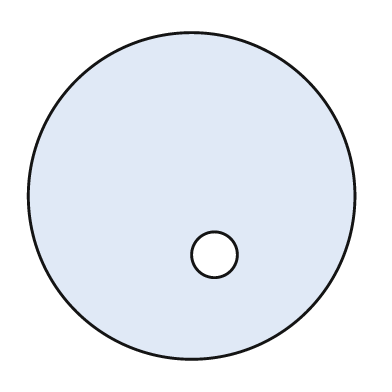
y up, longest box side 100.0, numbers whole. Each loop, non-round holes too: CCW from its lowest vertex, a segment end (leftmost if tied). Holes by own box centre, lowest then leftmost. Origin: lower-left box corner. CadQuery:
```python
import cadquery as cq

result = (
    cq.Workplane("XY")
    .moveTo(50.0, 50.0)
    .circle(50.0)
    .moveTo(57.0, 32.0)
    .circle(7.0)
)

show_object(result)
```